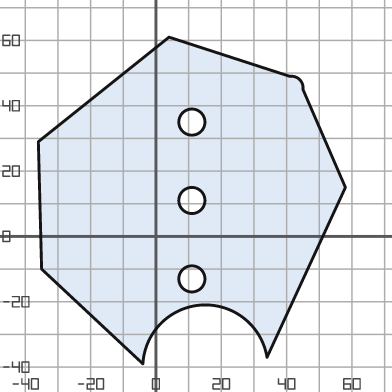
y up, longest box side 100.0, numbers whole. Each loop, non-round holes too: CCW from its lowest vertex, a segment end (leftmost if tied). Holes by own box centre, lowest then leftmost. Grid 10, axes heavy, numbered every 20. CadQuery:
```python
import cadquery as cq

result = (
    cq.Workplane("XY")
    .moveTo(-4.0, -39.0)
    .threePointArc((14.0, -21.0), (34.0, -37.0))
    .lineTo(58.0, 15.0)
    .lineTo(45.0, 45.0)
    .threePointArc((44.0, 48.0), (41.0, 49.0))
    .lineTo(4.0, 61.0)
    .lineTo(-36.0, 29.0)
    .lineTo(-35.0, -10.0)
    .close()
    .moveTo(11.0, -13.0)
    .circle(4.0)
    .moveTo(11.0, 11.0)
    .circle(4.0)
    .moveTo(11.0, 35.0)
    .circle(4.0)
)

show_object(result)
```